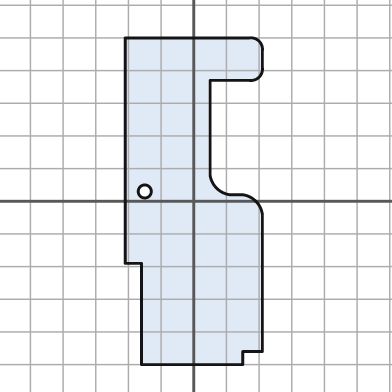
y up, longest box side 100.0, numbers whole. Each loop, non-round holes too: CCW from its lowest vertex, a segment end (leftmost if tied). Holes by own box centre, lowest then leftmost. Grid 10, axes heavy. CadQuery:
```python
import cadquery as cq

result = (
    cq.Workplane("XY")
    .moveTo(-16.0, -50.0)
    .lineTo(15.0, -50.0)
    .lineTo(15.0, -46.0)
    .lineTo(21.0, -46.0)
    .lineTo(21.0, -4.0)
    .threePointArc((19.0, 0.0), (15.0, 2.0))
    .lineTo(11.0, 2.0)
    .threePointArc((7.0, 4.0), (5.0, 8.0))
    .lineTo(5.0, 37.0)
    .lineTo(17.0, 37.0)
    .threePointArc((20.0, 38.0), (21.0, 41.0))
    .lineTo(21.0, 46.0)
    .threePointArc((20.0, 49.0), (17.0, 50.0))
    .lineTo(-21.0, 50.0)
    .lineTo(-21.0, -19.0)
    .lineTo(-16.0, -19.0)
    .close()
    .moveTo(-15.0, 3.0)
    .circle(2.0)
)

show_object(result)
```